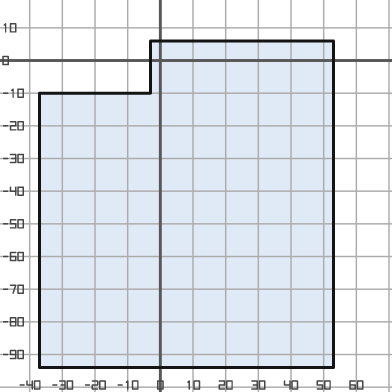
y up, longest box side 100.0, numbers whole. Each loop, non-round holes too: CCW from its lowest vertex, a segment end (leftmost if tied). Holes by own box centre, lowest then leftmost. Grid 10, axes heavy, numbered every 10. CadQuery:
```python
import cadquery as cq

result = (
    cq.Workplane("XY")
    .moveTo(-37.0, -94.0)
    .lineTo(53.0, -94.0)
    .lineTo(53.0, 6.0)
    .lineTo(-3.0, 6.0)
    .lineTo(-3.0, -10.0)
    .lineTo(-37.0, -10.0)
    .close()
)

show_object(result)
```